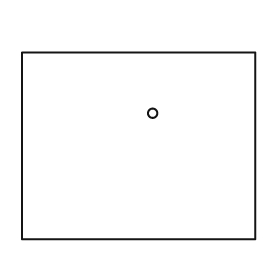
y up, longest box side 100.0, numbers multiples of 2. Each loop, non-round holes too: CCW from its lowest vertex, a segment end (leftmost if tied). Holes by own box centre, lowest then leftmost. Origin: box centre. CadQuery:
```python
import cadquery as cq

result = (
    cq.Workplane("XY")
    .moveTo(-50.0, -40.0)
    .lineTo(50.0, -40.0)
    .lineTo(50.0, 40.0)
    .lineTo(-50.0, 40.0)
    .close()
    .moveTo(6.0, 14.0)
    .circle(2.0)
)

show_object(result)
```